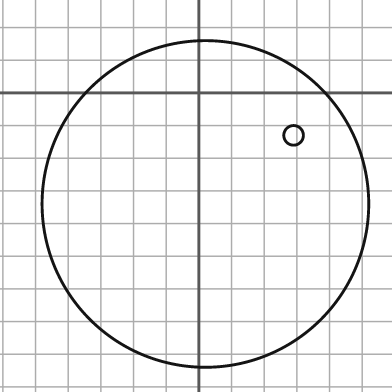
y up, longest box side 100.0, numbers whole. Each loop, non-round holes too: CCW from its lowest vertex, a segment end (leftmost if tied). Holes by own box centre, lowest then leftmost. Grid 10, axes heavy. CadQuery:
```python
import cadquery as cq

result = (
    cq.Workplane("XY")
    .moveTo(2.0, -34.0)
    .circle(50.0)
    .moveTo(29.0, -13.0)
    .circle(3.0)
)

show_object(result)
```